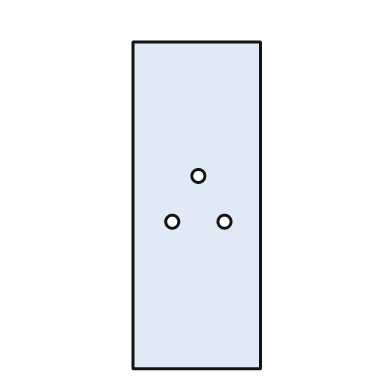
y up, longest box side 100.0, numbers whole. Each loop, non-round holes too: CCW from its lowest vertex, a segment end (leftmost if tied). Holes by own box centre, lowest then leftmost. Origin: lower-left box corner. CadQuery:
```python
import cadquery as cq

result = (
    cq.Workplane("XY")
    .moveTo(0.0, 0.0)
    .lineTo(39.0, 0.0)
    .lineTo(39.0, 100.0)
    .lineTo(0.0, 100.0)
    .close()
    .moveTo(12.0, 45.0)
    .circle(2.0)
    .moveTo(28.0, 45.0)
    .circle(2.0)
    .moveTo(20.0, 59.0)
    .circle(2.0)
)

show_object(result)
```